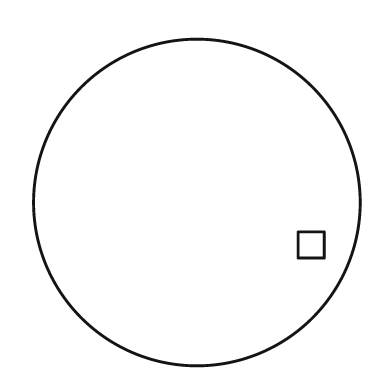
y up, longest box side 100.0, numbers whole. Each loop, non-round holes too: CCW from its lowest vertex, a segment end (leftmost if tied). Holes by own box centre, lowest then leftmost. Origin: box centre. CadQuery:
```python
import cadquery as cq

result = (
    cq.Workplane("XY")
    .moveTo(0.0, 0.0)
    .circle(50.0)
    .moveTo(31.0, -17.0)
    .lineTo(39.0, -17.0)
    .lineTo(39.0, -9.0)
    .lineTo(31.0, -9.0)
    .close()
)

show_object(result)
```